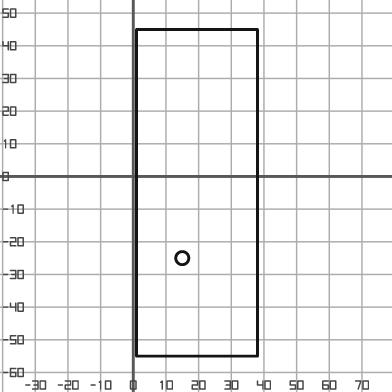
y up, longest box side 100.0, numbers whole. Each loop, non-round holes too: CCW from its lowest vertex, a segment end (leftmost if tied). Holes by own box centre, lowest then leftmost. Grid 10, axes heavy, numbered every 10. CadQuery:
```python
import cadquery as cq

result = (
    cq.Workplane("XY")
    .moveTo(1.0, -55.0)
    .lineTo(38.0, -55.0)
    .lineTo(38.0, 45.0)
    .lineTo(1.0, 45.0)
    .close()
    .moveTo(15.0, -25.0)
    .circle(2.0)
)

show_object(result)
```